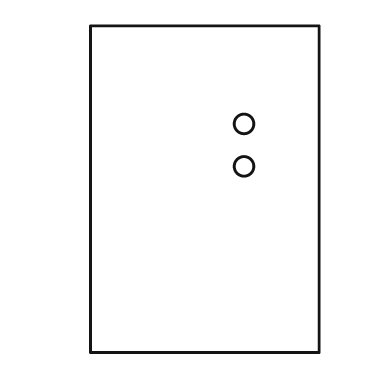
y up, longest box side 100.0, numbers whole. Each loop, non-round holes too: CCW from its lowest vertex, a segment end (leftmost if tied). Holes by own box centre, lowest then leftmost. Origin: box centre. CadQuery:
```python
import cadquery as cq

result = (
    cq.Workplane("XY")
    .moveTo(-35.0, -50.0)
    .lineTo(35.0, -50.0)
    .lineTo(35.0, 50.0)
    .lineTo(-35.0, 50.0)
    .close()
    .moveTo(12.0, 7.0)
    .circle(3.0)
    .moveTo(12.0, 20.0)
    .circle(3.0)
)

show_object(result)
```